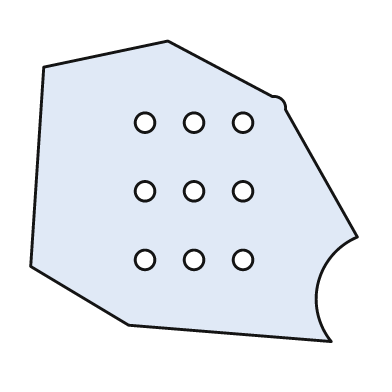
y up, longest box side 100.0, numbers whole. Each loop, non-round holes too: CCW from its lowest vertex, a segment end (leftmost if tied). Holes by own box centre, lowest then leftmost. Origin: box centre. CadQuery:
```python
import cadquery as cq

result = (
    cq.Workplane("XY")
    .moveTo(42.0, -46.0)
    .threePointArc((38.0, -28.0), (50.0, -14.0))
    .lineTo(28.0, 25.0)
    .threePointArc((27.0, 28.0), (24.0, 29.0))
    .lineTo(-8.0, 46.0)
    .lineTo(-46.0, 38.0)
    .lineTo(-50.0, -23.0)
    .lineTo(-20.0, -41.0)
    .close()
    .moveTo(-15.0, -21.0)
    .circle(3.0)
    .moveTo(0.0, -21.0)
    .circle(3.0)
    .moveTo(15.0, -21.0)
    .circle(3.0)
    .moveTo(-15.0, 0.0)
    .circle(3.0)
    .moveTo(0.0, 0.0)
    .circle(3.0)
    .moveTo(15.0, 0.0)
    .circle(3.0)
    .moveTo(-15.0, 21.0)
    .circle(3.0)
    .moveTo(0.0, 21.0)
    .circle(3.0)
    .moveTo(15.0, 21.0)
    .circle(3.0)
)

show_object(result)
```